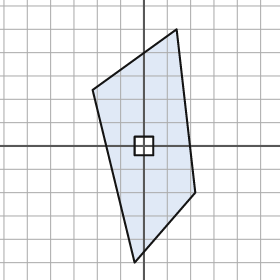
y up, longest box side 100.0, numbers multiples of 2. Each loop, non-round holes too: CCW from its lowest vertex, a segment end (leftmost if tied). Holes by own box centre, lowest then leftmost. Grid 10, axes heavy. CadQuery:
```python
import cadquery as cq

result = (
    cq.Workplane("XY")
    .moveTo(-4.0, -50.0)
    .lineTo(22.0, -20.0)
    .lineTo(14.0, 50.0)
    .lineTo(-22.0, 24.0)
    .close()
    .moveTo(-4.0, -4.0)
    .lineTo(4.0, -4.0)
    .lineTo(4.0, 4.0)
    .lineTo(-4.0, 4.0)
    .close()
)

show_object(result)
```